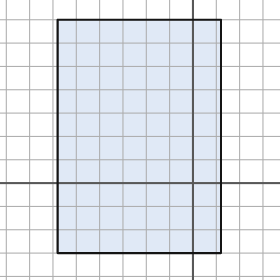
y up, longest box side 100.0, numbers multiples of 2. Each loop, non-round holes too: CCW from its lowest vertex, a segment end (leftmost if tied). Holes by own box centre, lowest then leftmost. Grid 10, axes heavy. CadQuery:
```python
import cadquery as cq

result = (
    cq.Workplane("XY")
    .moveTo(-58.0, -30.0)
    .lineTo(12.0, -30.0)
    .lineTo(12.0, 70.0)
    .lineTo(-58.0, 70.0)
    .close()
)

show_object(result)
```